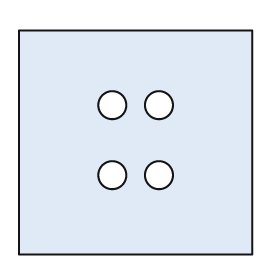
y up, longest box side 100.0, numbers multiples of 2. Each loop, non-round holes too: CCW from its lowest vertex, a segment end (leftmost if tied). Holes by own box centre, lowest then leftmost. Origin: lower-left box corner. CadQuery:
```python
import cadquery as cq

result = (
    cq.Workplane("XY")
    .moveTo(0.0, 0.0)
    .lineTo(100.0, 0.0)
    .lineTo(100.0, 96.0)
    .lineTo(0.0, 96.0)
    .close()
    .moveTo(40.0, 34.0)
    .circle(6.0)
    .moveTo(60.0, 34.0)
    .circle(6.0)
    .moveTo(40.0, 64.0)
    .circle(6.0)
    .moveTo(60.0, 64.0)
    .circle(6.0)
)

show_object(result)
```